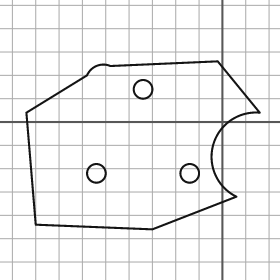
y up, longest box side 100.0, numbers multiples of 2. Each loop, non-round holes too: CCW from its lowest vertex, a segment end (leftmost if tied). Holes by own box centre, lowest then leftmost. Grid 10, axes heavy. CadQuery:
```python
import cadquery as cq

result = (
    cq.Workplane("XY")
    .moveTo(-30.0, -46.0)
    .lineTo(6.0, -32.0)
    .threePointArc((-4.0, -10.0), (16.0, 4.0))
    .lineTo(-2.0, 26.0)
    .lineTo(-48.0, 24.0)
    .threePointArc((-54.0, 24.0), (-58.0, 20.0))
    .lineTo(-84.0, 4.0)
    .lineTo(-80.0, -44.0)
    .close()
    .moveTo(-54.0, -22.0)
    .circle(4.0)
    .moveTo(-14.0, -22.0)
    .circle(4.0)
    .moveTo(-34.0, 14.0)
    .circle(4.0)
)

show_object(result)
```